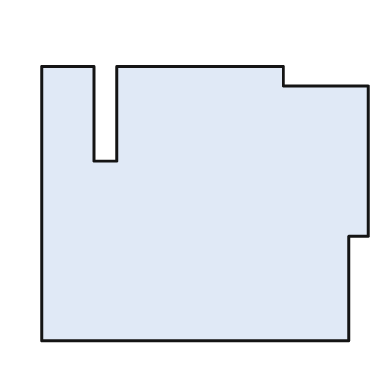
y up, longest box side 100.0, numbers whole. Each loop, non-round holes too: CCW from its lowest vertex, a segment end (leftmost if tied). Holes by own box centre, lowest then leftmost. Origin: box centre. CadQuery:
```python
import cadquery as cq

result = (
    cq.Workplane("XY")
    .moveTo(-50.0, -42.0)
    .lineTo(44.0, -42.0)
    .lineTo(44.0, -10.0)
    .lineTo(50.0, -10.0)
    .lineTo(50.0, 36.0)
    .lineTo(24.0, 36.0)
    .lineTo(24.0, 42.0)
    .lineTo(-27.0, 42.0)
    .lineTo(-27.0, 13.0)
    .lineTo(-34.0, 13.0)
    .lineTo(-34.0, 42.0)
    .lineTo(-50.0, 42.0)
    .close()
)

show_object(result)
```